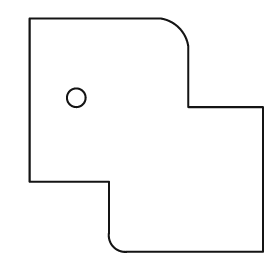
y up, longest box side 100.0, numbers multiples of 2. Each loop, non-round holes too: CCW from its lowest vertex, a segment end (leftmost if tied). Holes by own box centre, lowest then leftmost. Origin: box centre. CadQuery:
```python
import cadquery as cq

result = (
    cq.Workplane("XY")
    .moveTo(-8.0, -50.0)
    .lineTo(50.0, -50.0)
    .lineTo(50.0, 12.0)
    .lineTo(18.0, 12.0)
    .lineTo(18.0, 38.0)
    .threePointArc((14.0, 46.0), (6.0, 50.0))
    .lineTo(-50.0, 50.0)
    .lineTo(-50.0, -20.0)
    .lineTo(-16.0, -20.0)
    .lineTo(-16.0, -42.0)
    .threePointArc((-14.0, -48.0), (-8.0, -50.0))
    .close()
    .moveTo(-30.0, 16.0)
    .circle(4.0)
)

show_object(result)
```